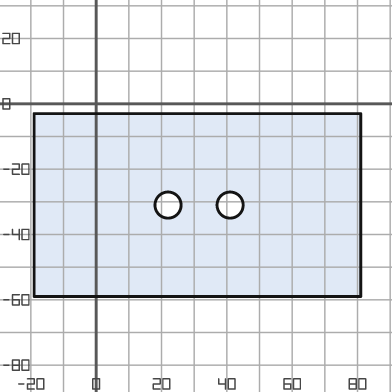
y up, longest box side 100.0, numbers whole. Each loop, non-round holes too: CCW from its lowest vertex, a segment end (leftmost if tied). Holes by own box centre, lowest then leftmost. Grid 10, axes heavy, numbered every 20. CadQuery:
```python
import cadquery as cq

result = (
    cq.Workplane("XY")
    .moveTo(-19.0, -59.0)
    .lineTo(81.0, -59.0)
    .lineTo(81.0, -3.0)
    .lineTo(-19.0, -3.0)
    .close()
    .moveTo(22.0, -31.0)
    .circle(4.0)
    .moveTo(41.0, -31.0)
    .circle(4.0)
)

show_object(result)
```